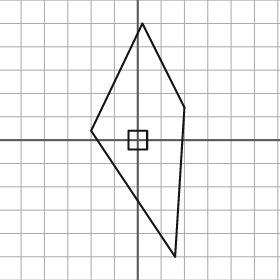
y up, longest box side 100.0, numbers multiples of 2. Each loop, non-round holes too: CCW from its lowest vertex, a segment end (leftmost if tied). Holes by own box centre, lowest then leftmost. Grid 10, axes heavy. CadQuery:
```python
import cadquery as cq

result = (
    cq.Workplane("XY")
    .moveTo(16.0, -50.0)
    .lineTo(20.0, 14.0)
    .lineTo(2.0, 50.0)
    .lineTo(-20.0, 4.0)
    .close()
    .moveTo(-4.0, -4.0)
    .lineTo(4.0, -4.0)
    .lineTo(4.0, 4.0)
    .lineTo(-4.0, 4.0)
    .close()
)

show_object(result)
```